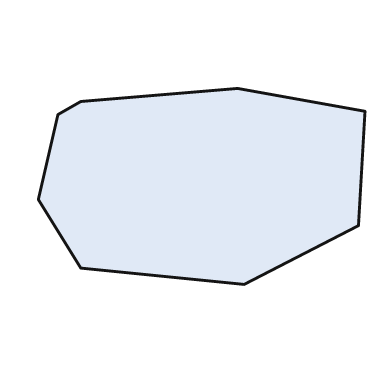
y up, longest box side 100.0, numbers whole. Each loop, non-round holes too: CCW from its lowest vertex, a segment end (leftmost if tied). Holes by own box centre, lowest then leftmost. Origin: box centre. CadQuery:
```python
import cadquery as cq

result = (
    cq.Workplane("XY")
    .moveTo(13.0, -30.0)
    .lineTo(48.0, -12.0)
    .lineTo(50.0, 23.0)
    .lineTo(11.0, 30.0)
    .lineTo(-37.0, 26.0)
    .lineTo(-44.0, 22.0)
    .lineTo(-50.0, -4.0)
    .lineTo(-37.0, -25.0)
    .close()
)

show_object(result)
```